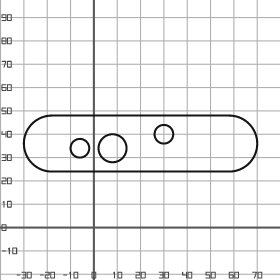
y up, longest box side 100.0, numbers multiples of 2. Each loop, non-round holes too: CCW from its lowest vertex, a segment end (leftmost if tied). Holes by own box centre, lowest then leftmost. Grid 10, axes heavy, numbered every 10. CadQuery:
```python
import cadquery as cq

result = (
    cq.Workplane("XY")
    .moveTo(-18.0, 24.0)
    .lineTo(58.0, 24.0)
    .threePointArc((70.0, 36.0), (58.0, 48.0))
    .lineTo(-18.0, 48.0)
    .threePointArc((-30.0, 36.0), (-18.0, 24.0))
    .close()
    .moveTo(-6.0, 34.0)
    .circle(4.0)
    .moveTo(8.0, 34.0)
    .circle(6.0)
    .moveTo(30.0, 40.0)
    .circle(4.0)
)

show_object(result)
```